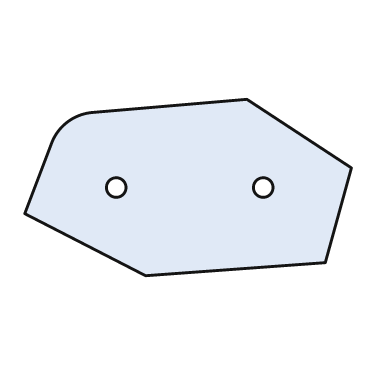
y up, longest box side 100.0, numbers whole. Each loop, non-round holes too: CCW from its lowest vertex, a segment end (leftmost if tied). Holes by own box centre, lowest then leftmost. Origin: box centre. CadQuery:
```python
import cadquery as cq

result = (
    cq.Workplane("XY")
    .moveTo(-13.0, -27.0)
    .lineTo(42.0, -23.0)
    .lineTo(50.0, 6.0)
    .lineTo(18.0, 27.0)
    .lineTo(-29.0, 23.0)
    .threePointArc((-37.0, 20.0), (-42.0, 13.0))
    .lineTo(-50.0, -8.0)
    .close()
    .moveTo(-22.0, 0.0)
    .circle(3.0)
    .moveTo(23.0, 0.0)
    .circle(3.0)
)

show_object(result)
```